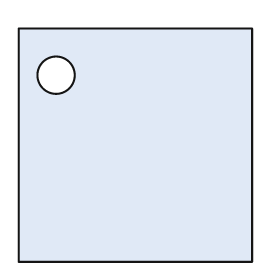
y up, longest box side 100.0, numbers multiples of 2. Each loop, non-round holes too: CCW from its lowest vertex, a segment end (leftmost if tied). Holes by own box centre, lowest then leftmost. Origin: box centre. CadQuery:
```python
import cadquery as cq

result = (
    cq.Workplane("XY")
    .moveTo(-50.0, -50.0)
    .lineTo(50.0, -50.0)
    .lineTo(50.0, 50.0)
    .lineTo(-50.0, 50.0)
    .close()
    .moveTo(-34.0, 30.0)
    .circle(8.0)
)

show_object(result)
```